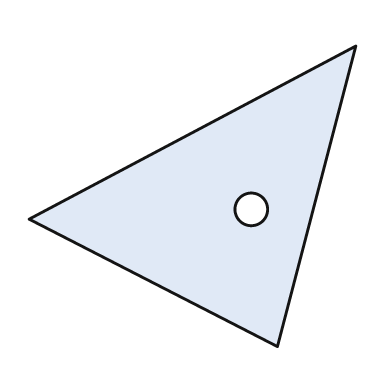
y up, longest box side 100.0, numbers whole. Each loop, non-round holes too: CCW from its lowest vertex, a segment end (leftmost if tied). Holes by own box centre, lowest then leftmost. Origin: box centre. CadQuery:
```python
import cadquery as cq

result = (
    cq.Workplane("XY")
    .moveTo(26.0, -46.0)
    .lineTo(50.0, 46.0)
    .lineTo(-50.0, -7.0)
    .close()
    .moveTo(18.0, -4.0)
    .circle(5.0)
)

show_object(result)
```